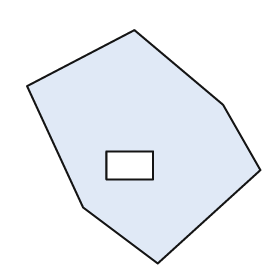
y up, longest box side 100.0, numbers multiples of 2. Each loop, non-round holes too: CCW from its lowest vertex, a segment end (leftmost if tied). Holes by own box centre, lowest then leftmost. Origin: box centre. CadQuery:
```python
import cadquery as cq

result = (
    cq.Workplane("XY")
    .moveTo(6.0, -50.0)
    .lineTo(50.0, -10.0)
    .lineTo(34.0, 18.0)
    .lineTo(-4.0, 50.0)
    .lineTo(-50.0, 26.0)
    .lineTo(-26.0, -26.0)
    .close()
    .moveTo(-16.0, -14.0)
    .lineTo(4.0, -14.0)
    .lineTo(4.0, -2.0)
    .lineTo(-16.0, -2.0)
    .close()
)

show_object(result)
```